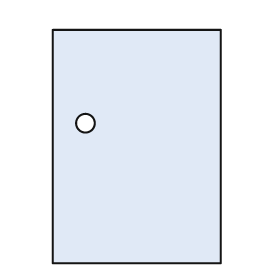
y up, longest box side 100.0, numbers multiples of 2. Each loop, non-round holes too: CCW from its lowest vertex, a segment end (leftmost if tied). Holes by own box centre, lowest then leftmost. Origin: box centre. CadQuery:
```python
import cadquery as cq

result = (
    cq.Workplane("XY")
    .moveTo(-36.0, -50.0)
    .lineTo(36.0, -50.0)
    .lineTo(36.0, 50.0)
    .lineTo(-36.0, 50.0)
    .close()
    .moveTo(-22.0, 10.0)
    .circle(4.0)
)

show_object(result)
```